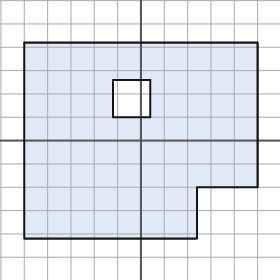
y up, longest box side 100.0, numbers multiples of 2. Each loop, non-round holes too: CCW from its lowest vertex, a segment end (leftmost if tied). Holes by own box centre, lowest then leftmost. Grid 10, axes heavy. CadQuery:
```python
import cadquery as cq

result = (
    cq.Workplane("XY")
    .moveTo(-50.0, -42.0)
    .lineTo(24.0, -42.0)
    .lineTo(24.0, -20.0)
    .lineTo(50.0, -20.0)
    .lineTo(50.0, 42.0)
    .lineTo(-50.0, 42.0)
    .close()
    .moveTo(-12.0, 10.0)
    .lineTo(4.0, 10.0)
    .lineTo(4.0, 26.0)
    .lineTo(-12.0, 26.0)
    .close()
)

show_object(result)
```